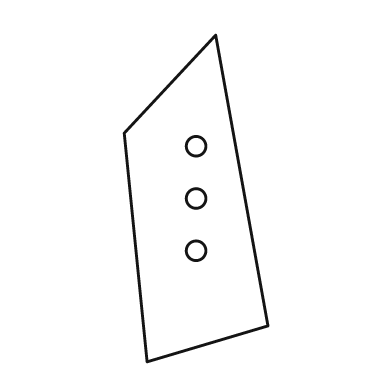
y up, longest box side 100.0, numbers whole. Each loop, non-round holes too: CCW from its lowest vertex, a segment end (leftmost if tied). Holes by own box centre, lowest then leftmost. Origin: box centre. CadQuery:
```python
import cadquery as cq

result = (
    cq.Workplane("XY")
    .moveTo(-15.0, -50.0)
    .lineTo(22.0, -39.0)
    .lineTo(6.0, 50.0)
    .lineTo(-22.0, 20.0)
    .close()
    .moveTo(0.0, -16.0)
    .circle(3.0)
    .moveTo(0.0, 0.0)
    .circle(3.0)
    .moveTo(0.0, 16.0)
    .circle(3.0)
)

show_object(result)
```